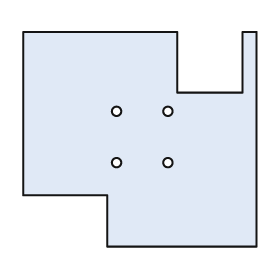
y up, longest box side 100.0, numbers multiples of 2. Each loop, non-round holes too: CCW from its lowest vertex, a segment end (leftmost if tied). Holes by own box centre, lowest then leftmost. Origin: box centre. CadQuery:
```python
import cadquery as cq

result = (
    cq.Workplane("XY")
    .moveTo(-14.0, -46.0)
    .lineTo(50.0, -46.0)
    .lineTo(50.0, 46.0)
    .lineTo(44.0, 46.0)
    .lineTo(44.0, 20.0)
    .lineTo(16.0, 20.0)
    .lineTo(16.0, 46.0)
    .lineTo(-50.0, 46.0)
    .lineTo(-50.0, -24.0)
    .lineTo(-14.0, -24.0)
    .close()
    .moveTo(-10.0, -10.0)
    .circle(2.0)
    .moveTo(12.0, -10.0)
    .circle(2.0)
    .moveTo(-10.0, 12.0)
    .circle(2.0)
    .moveTo(12.0, 12.0)
    .circle(2.0)
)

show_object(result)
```